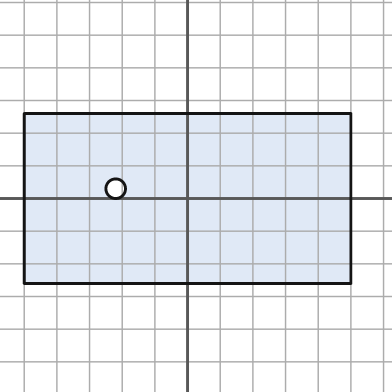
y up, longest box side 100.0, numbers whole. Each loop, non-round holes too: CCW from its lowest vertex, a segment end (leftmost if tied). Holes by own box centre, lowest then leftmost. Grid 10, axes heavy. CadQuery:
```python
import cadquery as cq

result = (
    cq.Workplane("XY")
    .moveTo(-50.0, -26.0)
    .lineTo(50.0, -26.0)
    .lineTo(50.0, 26.0)
    .lineTo(-50.0, 26.0)
    .close()
    .moveTo(-22.0, 3.0)
    .circle(3.0)
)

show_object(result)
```